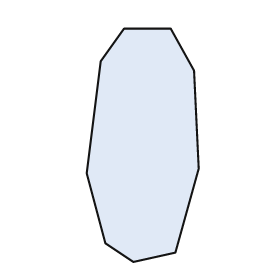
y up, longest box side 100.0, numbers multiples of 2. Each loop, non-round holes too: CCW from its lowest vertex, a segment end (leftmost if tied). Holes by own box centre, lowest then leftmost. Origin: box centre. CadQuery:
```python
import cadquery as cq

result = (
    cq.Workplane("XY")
    .moveTo(-4.0, -50.0)
    .lineTo(14.0, -46.0)
    .lineTo(24.0, -10.0)
    .lineTo(22.0, 32.0)
    .lineTo(12.0, 50.0)
    .lineTo(-8.0, 50.0)
    .lineTo(-18.0, 36.0)
    .lineTo(-24.0, -12.0)
    .lineTo(-16.0, -42.0)
    .close()
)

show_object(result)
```